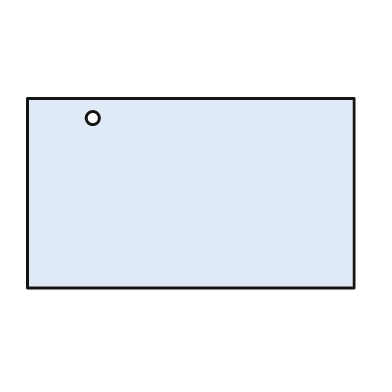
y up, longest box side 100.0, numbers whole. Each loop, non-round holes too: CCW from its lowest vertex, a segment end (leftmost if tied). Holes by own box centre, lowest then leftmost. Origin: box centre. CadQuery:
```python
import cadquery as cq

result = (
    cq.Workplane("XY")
    .moveTo(-50.0, -29.0)
    .lineTo(50.0, -29.0)
    .lineTo(50.0, 29.0)
    .lineTo(-50.0, 29.0)
    .close()
    .moveTo(-30.0, 23.0)
    .circle(2.0)
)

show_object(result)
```